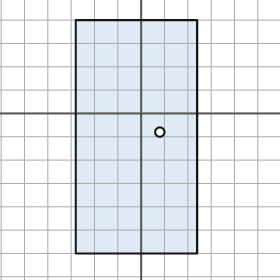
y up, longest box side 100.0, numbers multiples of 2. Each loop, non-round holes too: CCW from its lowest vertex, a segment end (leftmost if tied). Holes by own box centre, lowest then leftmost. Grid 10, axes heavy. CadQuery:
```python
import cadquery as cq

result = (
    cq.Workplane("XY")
    .moveTo(-28.0, -60.0)
    .lineTo(24.0, -60.0)
    .lineTo(24.0, 40.0)
    .lineTo(-28.0, 40.0)
    .close()
    .moveTo(8.0, -8.0)
    .circle(2.0)
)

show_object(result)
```